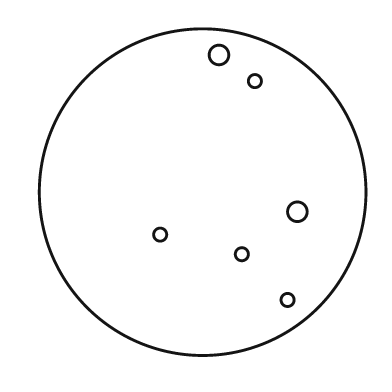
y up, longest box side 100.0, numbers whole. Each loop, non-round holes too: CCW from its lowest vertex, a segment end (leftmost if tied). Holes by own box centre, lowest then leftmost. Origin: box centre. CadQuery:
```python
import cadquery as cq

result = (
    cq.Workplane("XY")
    .moveTo(0.0, 0.0)
    .circle(50.0)
    .moveTo(26.0, -33.0)
    .circle(2.0)
    .moveTo(12.0, -19.0)
    .circle(2.0)
    .moveTo(-13.0, -13.0)
    .circle(2.0)
    .moveTo(29.0, -6.0)
    .circle(3.0)
    .moveTo(16.0, 34.0)
    .circle(2.0)
    .moveTo(5.0, 42.0)
    .circle(3.0)
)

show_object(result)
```